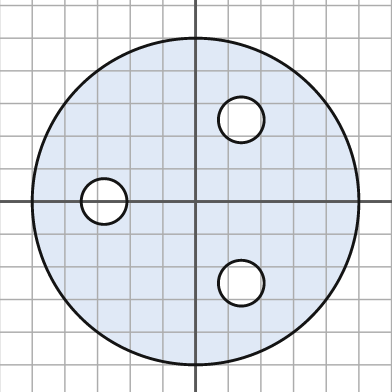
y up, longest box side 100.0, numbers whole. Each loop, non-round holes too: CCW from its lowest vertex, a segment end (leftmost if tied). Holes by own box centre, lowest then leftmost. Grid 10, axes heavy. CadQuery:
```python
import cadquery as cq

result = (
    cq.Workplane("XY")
    .moveTo(0.0, 0.0)
    .circle(50.0)
    .moveTo(14.0, -25.0)
    .circle(7.0)
    .moveTo(-28.0, 0.0)
    .circle(7.0)
    .moveTo(14.0, 25.0)
    .circle(7.0)
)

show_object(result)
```